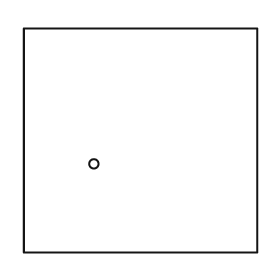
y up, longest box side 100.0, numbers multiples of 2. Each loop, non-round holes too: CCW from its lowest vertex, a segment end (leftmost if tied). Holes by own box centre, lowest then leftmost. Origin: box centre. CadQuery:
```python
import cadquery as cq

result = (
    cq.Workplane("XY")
    .moveTo(-50.0, -48.0)
    .lineTo(50.0, -48.0)
    .lineTo(50.0, 48.0)
    .lineTo(-50.0, 48.0)
    .close()
    .moveTo(-20.0, -10.0)
    .circle(2.0)
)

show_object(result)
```